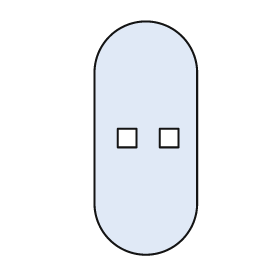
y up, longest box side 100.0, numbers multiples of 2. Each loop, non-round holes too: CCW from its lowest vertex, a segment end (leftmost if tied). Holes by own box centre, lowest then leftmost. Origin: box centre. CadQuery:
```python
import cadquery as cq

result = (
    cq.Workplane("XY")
    .moveTo(-22.0, -28.0)
    .threePointArc((0.0, -50.0), (22.0, -28.0))
    .lineTo(22.0, 28.0)
    .threePointArc((0.0, 50.0), (-22.0, 28.0))
    .close()
    .moveTo(-12.0, -4.0)
    .lineTo(-4.0, -4.0)
    .lineTo(-4.0, 4.0)
    .lineTo(-12.0, 4.0)
    .close()
    .moveTo(6.0, -4.0)
    .lineTo(14.0, -4.0)
    .lineTo(14.0, 4.0)
    .lineTo(6.0, 4.0)
    .close()
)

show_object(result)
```